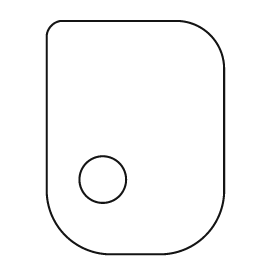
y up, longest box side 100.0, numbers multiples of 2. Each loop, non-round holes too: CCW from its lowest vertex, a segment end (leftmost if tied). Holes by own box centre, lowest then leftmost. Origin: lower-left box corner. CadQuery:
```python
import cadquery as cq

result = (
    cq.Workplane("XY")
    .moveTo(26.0, 0.0)
    .lineTo(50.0, 0.0)
    .threePointArc((68.0, 8.0), (76.0, 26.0))
    .lineTo(76.0, 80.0)
    .threePointArc((70.0, 94.0), (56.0, 100.0))
    .lineTo(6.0, 100.0)
    .threePointArc((2.0, 98.0), (0.0, 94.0))
    .lineTo(0.0, 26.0)
    .threePointArc((8.0, 8.0), (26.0, 0.0))
    .close()
    .moveTo(24.0, 32.0)
    .circle(10.0)
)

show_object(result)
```